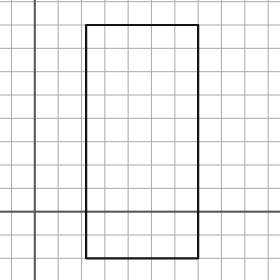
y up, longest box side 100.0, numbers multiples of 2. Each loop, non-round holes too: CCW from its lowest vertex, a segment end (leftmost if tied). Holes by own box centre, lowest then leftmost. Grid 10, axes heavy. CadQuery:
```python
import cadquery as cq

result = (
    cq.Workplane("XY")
    .moveTo(22.0, -20.0)
    .lineTo(70.0, -20.0)
    .lineTo(70.0, 80.0)
    .lineTo(22.0, 80.0)
    .close()
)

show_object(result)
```